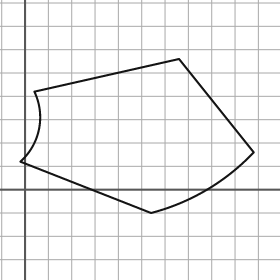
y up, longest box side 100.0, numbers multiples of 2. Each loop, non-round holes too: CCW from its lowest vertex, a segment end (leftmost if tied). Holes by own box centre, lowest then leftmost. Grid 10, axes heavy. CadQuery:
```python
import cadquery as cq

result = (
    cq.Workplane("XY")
    .moveTo(54.0, -10.0)
    .threePointArc((78.0, 0.0), (98.0, 16.0))
    .lineTo(66.0, 56.0)
    .lineTo(4.0, 42.0)
    .threePointArc((6.0, 26.0), (-2.0, 12.0))
    .close()
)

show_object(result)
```